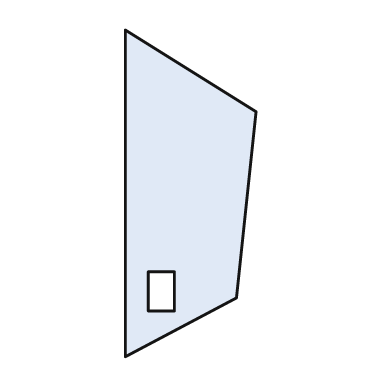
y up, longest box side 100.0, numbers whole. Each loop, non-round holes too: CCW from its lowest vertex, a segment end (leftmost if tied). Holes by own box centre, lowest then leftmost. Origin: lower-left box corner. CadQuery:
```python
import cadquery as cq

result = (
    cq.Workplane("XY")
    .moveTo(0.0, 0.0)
    .lineTo(34.0, 18.0)
    .lineTo(40.0, 75.0)
    .lineTo(0.0, 100.0)
    .close()
    .moveTo(7.0, 14.0)
    .lineTo(15.0, 14.0)
    .lineTo(15.0, 26.0)
    .lineTo(7.0, 26.0)
    .close()
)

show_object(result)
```